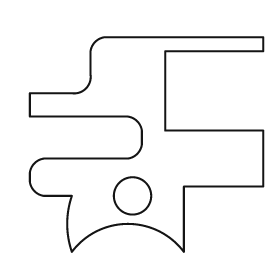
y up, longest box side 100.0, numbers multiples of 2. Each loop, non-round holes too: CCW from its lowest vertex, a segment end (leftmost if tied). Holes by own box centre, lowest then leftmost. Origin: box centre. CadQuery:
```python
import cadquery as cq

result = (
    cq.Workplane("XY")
    .moveTo(-32.0, -46.0)
    .threePointArc((-8.0, -34.0), (16.0, -46.0))
    .lineTo(16.0, -18.0)
    .lineTo(50.0, -18.0)
    .lineTo(50.0, 6.0)
    .lineTo(8.0, 6.0)
    .lineTo(8.0, 40.0)
    .lineTo(50.0, 40.0)
    .lineTo(50.0, 46.0)
    .lineTo(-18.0, 46.0)
    .threePointArc((-22.0, 44.0), (-24.0, 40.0))
    .lineTo(-24.0, 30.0)
    .threePointArc((-26.0, 24.0), (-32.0, 22.0))
    .lineTo(-50.0, 22.0)
    .lineTo(-50.0, 12.0)
    .lineTo(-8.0, 12.0)
    .threePointArc((-4.0, 10.0), (-2.0, 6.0))
    .lineTo(-2.0, 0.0)
    .threePointArc((-4.0, -4.0), (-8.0, -6.0))
    .lineTo(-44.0, -6.0)
    .threePointArc((-48.0, -8.0), (-50.0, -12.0))
    .lineTo(-50.0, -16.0)
    .threePointArc((-48.0, -20.0), (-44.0, -22.0))
    .lineTo(-32.0, -22.0)
    .threePointArc((-34.0, -34.0), (-32.0, -46.0))
    .close()
    .moveTo(-6.0, -22.0)
    .circle(8.0)
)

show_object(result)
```